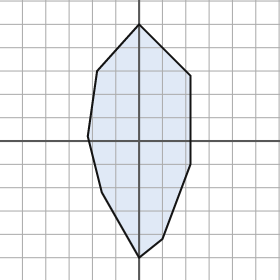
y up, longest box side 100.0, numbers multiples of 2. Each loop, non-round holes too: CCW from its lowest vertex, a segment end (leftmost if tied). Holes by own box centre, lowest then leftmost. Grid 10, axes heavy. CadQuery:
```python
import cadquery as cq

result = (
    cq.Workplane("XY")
    .moveTo(0.0, -50.0)
    .lineTo(10.0, -42.0)
    .lineTo(22.0, -10.0)
    .lineTo(22.0, 28.0)
    .lineTo(0.0, 50.0)
    .lineTo(-18.0, 30.0)
    .lineTo(-22.0, 2.0)
    .lineTo(-16.0, -22.0)
    .close()
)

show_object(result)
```